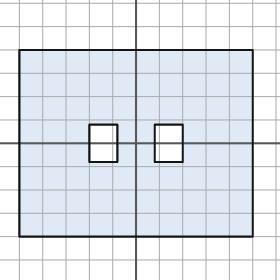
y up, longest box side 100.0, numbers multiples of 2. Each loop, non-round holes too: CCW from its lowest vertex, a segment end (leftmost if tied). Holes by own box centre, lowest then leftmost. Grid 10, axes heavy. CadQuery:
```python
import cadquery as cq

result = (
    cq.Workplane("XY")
    .moveTo(-50.0, -40.0)
    .lineTo(50.0, -40.0)
    .lineTo(50.0, 40.0)
    .lineTo(-50.0, 40.0)
    .close()
    .moveTo(-20.0, -8.0)
    .lineTo(-8.0, -8.0)
    .lineTo(-8.0, 8.0)
    .lineTo(-20.0, 8.0)
    .close()
    .moveTo(8.0, -8.0)
    .lineTo(20.0, -8.0)
    .lineTo(20.0, 8.0)
    .lineTo(8.0, 8.0)
    .close()
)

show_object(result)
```